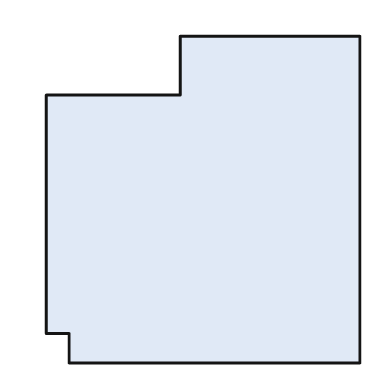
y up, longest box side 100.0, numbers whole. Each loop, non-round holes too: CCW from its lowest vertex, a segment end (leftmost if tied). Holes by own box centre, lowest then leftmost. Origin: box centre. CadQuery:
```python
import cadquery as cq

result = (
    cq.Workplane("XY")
    .moveTo(-41.0, -50.0)
    .lineTo(48.0, -50.0)
    .lineTo(48.0, 50.0)
    .lineTo(-7.0, 50.0)
    .lineTo(-7.0, 32.0)
    .lineTo(-48.0, 32.0)
    .lineTo(-48.0, -41.0)
    .lineTo(-41.0, -41.0)
    .close()
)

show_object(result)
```